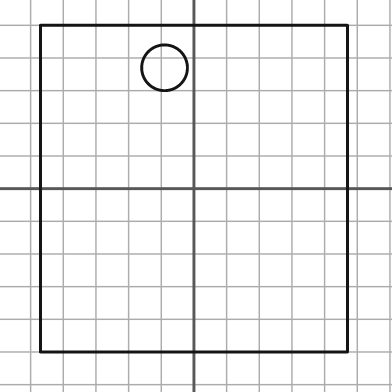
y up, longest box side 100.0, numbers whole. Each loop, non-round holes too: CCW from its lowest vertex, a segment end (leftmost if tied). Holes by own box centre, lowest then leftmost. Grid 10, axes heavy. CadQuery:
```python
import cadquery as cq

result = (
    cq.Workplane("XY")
    .moveTo(-47.0, -50.0)
    .lineTo(47.0, -50.0)
    .lineTo(47.0, 50.0)
    .lineTo(-47.0, 50.0)
    .close()
    .moveTo(-9.0, 37.0)
    .circle(7.0)
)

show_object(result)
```